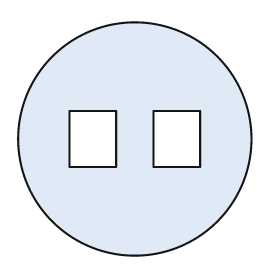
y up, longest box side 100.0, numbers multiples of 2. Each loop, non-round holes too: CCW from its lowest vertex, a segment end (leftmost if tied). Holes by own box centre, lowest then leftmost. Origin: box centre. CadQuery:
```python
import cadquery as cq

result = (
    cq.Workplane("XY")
    .moveTo(0.0, 0.0)
    .circle(50.0)
    .moveTo(-28.0, -12.0)
    .lineTo(-8.0, -12.0)
    .lineTo(-8.0, 12.0)
    .lineTo(-28.0, 12.0)
    .close()
    .moveTo(8.0, -12.0)
    .lineTo(28.0, -12.0)
    .lineTo(28.0, 12.0)
    .lineTo(8.0, 12.0)
    .close()
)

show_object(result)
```